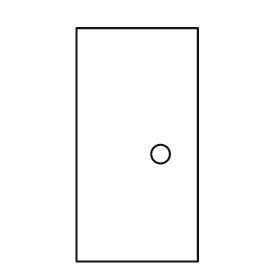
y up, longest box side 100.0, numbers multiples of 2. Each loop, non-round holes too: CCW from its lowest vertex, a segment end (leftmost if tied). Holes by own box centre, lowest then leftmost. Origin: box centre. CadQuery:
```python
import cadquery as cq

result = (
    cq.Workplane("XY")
    .moveTo(-26.0, -50.0)
    .lineTo(26.0, -50.0)
    .lineTo(26.0, 50.0)
    .lineTo(-26.0, 50.0)
    .close()
    .moveTo(10.0, -4.0)
    .circle(4.0)
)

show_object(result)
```